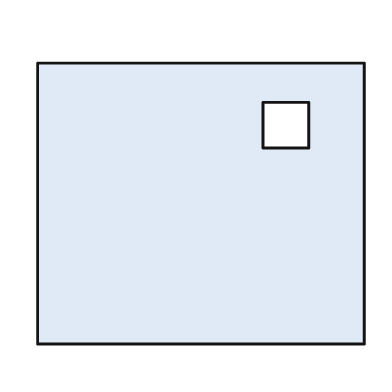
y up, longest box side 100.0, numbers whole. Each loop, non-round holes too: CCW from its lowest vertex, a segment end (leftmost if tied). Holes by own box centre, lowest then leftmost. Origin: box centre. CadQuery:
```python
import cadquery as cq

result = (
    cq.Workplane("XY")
    .moveTo(-50.0, -43.0)
    .lineTo(50.0, -43.0)
    .lineTo(50.0, 43.0)
    .lineTo(-50.0, 43.0)
    .close()
    .moveTo(19.0, 17.0)
    .lineTo(33.0, 17.0)
    .lineTo(33.0, 31.0)
    .lineTo(19.0, 31.0)
    .close()
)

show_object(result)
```